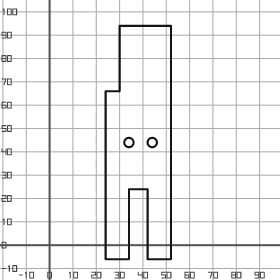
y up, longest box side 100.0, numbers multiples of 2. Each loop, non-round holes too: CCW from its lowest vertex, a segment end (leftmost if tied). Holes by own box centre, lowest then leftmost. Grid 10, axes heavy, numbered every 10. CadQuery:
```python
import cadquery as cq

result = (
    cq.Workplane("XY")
    .moveTo(24.0, -6.0)
    .lineTo(34.0, -6.0)
    .lineTo(34.0, 24.0)
    .lineTo(42.0, 24.0)
    .lineTo(42.0, -6.0)
    .lineTo(52.0, -6.0)
    .lineTo(52.0, 94.0)
    .lineTo(30.0, 94.0)
    .lineTo(30.0, 66.0)
    .lineTo(24.0, 66.0)
    .close()
    .moveTo(34.0, 44.0)
    .circle(2.0)
    .moveTo(44.0, 44.0)
    .circle(2.0)
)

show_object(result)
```